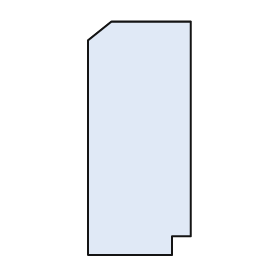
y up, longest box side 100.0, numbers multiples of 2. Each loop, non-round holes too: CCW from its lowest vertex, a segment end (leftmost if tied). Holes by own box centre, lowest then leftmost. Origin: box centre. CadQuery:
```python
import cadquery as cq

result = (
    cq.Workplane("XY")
    .moveTo(-22.0, -50.0)
    .lineTo(14.0, -50.0)
    .lineTo(14.0, -42.0)
    .lineTo(22.0, -42.0)
    .lineTo(22.0, 50.0)
    .lineTo(-12.0, 50.0)
    .lineTo(-22.0, 42.0)
    .close()
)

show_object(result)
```